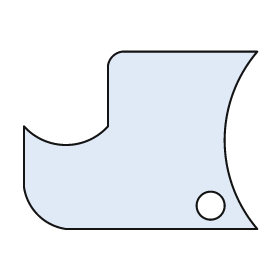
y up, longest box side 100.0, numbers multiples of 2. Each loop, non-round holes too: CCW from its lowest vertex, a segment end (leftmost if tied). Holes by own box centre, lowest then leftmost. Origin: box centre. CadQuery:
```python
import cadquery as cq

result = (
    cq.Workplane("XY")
    .moveTo(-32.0, -38.0)
    .lineTo(50.0, -38.0)
    .threePointArc((36.0, 0.0), (50.0, 38.0))
    .lineTo(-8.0, 38.0)
    .threePointArc((-12.0, 36.0), (-14.0, 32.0))
    .lineTo(-14.0, 6.0)
    .threePointArc((-32.0, -2.0), (-50.0, 6.0))
    .lineTo(-50.0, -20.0)
    .threePointArc((-44.0, -32.0), (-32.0, -38.0))
    .close()
    .moveTo(30.0, -28.0)
    .circle(6.0)
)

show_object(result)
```